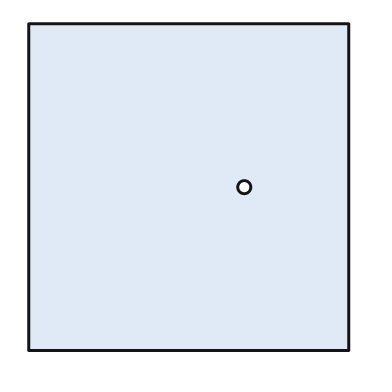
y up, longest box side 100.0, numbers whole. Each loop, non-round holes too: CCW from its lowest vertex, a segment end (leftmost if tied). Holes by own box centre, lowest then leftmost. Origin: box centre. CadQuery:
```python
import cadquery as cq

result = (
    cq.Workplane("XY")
    .moveTo(-49.0, -50.0)
    .lineTo(49.0, -50.0)
    .lineTo(49.0, 50.0)
    .lineTo(-49.0, 50.0)
    .close()
    .moveTo(17.0, 0.0)
    .circle(2.0)
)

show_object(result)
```